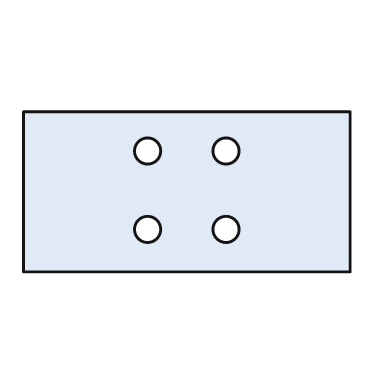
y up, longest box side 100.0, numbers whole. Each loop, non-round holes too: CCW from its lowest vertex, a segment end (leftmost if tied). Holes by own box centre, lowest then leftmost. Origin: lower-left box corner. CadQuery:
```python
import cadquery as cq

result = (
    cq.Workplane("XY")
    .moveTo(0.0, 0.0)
    .lineTo(100.0, 0.0)
    .lineTo(100.0, 49.0)
    .lineTo(0.0, 49.0)
    .close()
    .moveTo(38.0, 13.0)
    .circle(4.0)
    .moveTo(62.0, 13.0)
    .circle(4.0)
    .moveTo(38.0, 37.0)
    .circle(4.0)
    .moveTo(62.0, 37.0)
    .circle(4.0)
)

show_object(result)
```